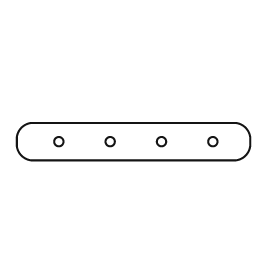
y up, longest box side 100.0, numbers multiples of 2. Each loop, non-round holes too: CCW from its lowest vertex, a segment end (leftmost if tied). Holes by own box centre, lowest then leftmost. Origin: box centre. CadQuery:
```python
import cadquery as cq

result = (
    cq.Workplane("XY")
    .moveTo(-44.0, -8.0)
    .lineTo(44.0, -8.0)
    .threePointArc((48.0, -6.0), (50.0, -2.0))
    .lineTo(50.0, 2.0)
    .threePointArc((48.0, 6.0), (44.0, 8.0))
    .lineTo(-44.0, 8.0)
    .threePointArc((-48.0, 6.0), (-50.0, 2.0))
    .lineTo(-50.0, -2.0)
    .threePointArc((-48.0, -6.0), (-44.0, -8.0))
    .close()
    .moveTo(-32.0, 0.0)
    .circle(2.0)
    .moveTo(-10.0, 0.0)
    .circle(2.0)
    .moveTo(12.0, 0.0)
    .circle(2.0)
    .moveTo(34.0, 0.0)
    .circle(2.0)
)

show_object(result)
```